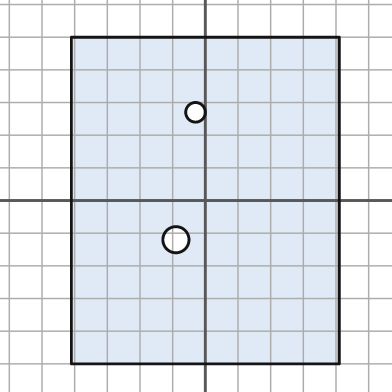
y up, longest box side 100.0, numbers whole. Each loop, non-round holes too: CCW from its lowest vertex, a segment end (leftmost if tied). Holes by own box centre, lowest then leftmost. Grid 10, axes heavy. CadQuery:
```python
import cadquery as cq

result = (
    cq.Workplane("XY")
    .moveTo(-41.0, -50.0)
    .lineTo(41.0, -50.0)
    .lineTo(41.0, 50.0)
    .lineTo(-41.0, 50.0)
    .close()
    .moveTo(-9.0, -12.0)
    .circle(4.0)
    .moveTo(-3.0, 27.0)
    .circle(3.0)
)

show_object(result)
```